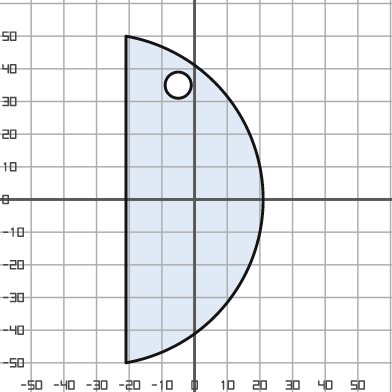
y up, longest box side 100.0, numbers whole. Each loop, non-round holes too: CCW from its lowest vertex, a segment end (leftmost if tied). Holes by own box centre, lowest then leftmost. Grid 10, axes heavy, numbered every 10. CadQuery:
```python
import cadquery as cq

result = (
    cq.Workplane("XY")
    .moveTo(-21.0, -50.0)
    .threePointArc((21.0, 0.0), (-21.0, 50.0))
    .close()
    .moveTo(-5.0, 35.0)
    .circle(4.0)
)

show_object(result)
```